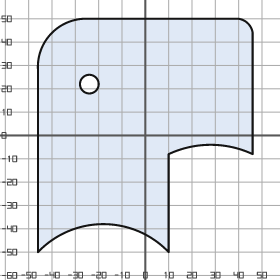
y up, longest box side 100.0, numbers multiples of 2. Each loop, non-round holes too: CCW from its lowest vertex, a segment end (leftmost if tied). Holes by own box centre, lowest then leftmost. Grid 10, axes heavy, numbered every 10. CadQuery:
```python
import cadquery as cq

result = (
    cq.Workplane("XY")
    .moveTo(-46.0, -50.0)
    .threePointArc((-18.0, -38.0), (10.0, -50.0))
    .lineTo(10.0, -8.0)
    .threePointArc((28.0, -4.0), (46.0, -8.0))
    .lineTo(46.0, 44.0)
    .threePointArc((44.0, 48.0), (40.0, 50.0))
    .lineTo(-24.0, 50.0)
    .threePointArc((-40.0, 44.0), (-46.0, 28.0))
    .close()
    .moveTo(-24.0, 22.0)
    .circle(4.0)
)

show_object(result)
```